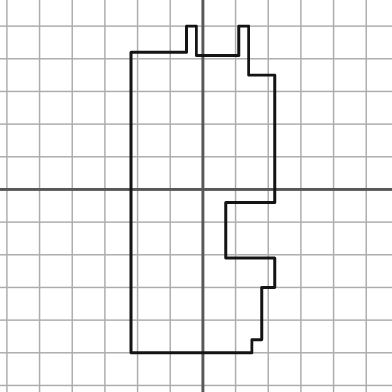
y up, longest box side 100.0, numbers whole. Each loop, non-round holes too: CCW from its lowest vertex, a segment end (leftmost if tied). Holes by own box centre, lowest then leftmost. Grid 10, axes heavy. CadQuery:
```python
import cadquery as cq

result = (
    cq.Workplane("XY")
    .moveTo(-22.0, -50.0)
    .lineTo(15.0, -50.0)
    .lineTo(15.0, -46.0)
    .lineTo(18.0, -46.0)
    .lineTo(18.0, -30.0)
    .lineTo(22.0, -30.0)
    .lineTo(22.0, -21.0)
    .lineTo(7.0, -21.0)
    .lineTo(7.0, -4.0)
    .lineTo(22.0, -4.0)
    .lineTo(22.0, 35.0)
    .lineTo(14.0, 35.0)
    .lineTo(14.0, 50.0)
    .lineTo(11.0, 50.0)
    .lineTo(11.0, 41.0)
    .lineTo(-2.0, 41.0)
    .lineTo(-2.0, 50.0)
    .lineTo(-5.0, 50.0)
    .lineTo(-5.0, 42.0)
    .lineTo(-22.0, 42.0)
    .close()
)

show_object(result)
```